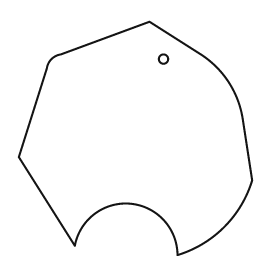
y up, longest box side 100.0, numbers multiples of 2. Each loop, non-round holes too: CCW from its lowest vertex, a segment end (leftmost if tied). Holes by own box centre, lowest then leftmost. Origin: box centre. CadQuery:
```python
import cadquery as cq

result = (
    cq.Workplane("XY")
    .moveTo(18.0, -50.0)
    .threePointArc((38.0, -38.0), (50.0, -18.0))
    .lineTo(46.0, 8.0)
    .threePointArc((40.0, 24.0), (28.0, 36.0))
    .lineTo(6.0, 50.0)
    .lineTo(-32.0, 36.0)
    .threePointArc((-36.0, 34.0), (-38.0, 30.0))
    .lineTo(-50.0, -8.0)
    .lineTo(-26.0, -46.0)
    .threePointArc((-2.0, -28.0), (18.0, -50.0))
    .close()
    .moveTo(12.0, 34.0)
    .circle(2.0)
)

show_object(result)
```